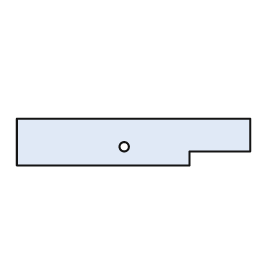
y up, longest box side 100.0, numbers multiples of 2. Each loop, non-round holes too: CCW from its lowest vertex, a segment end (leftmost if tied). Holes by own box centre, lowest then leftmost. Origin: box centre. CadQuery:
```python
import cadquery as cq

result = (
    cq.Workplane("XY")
    .moveTo(-50.0, -10.0)
    .lineTo(24.0, -10.0)
    .lineTo(24.0, -4.0)
    .lineTo(50.0, -4.0)
    .lineTo(50.0, 10.0)
    .lineTo(-50.0, 10.0)
    .close()
    .moveTo(-4.0, -2.0)
    .circle(2.0)
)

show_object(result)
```